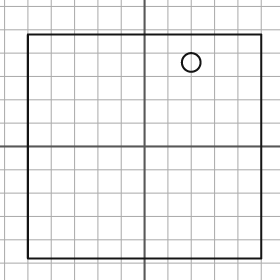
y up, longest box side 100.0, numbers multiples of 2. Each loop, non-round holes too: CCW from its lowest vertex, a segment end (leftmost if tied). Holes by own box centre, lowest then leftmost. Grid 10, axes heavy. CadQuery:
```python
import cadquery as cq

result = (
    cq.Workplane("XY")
    .moveTo(-50.0, -48.0)
    .lineTo(50.0, -48.0)
    .lineTo(50.0, 48.0)
    .lineTo(-50.0, 48.0)
    .close()
    .moveTo(20.0, 36.0)
    .circle(4.0)
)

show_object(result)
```